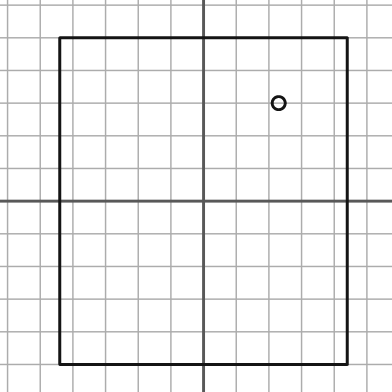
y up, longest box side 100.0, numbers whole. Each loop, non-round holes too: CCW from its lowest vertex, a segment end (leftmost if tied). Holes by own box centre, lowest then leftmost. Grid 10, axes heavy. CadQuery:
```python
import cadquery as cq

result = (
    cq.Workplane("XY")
    .moveTo(-44.0, -50.0)
    .lineTo(44.0, -50.0)
    .lineTo(44.0, 50.0)
    .lineTo(-44.0, 50.0)
    .close()
    .moveTo(23.0, 30.0)
    .circle(2.0)
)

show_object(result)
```